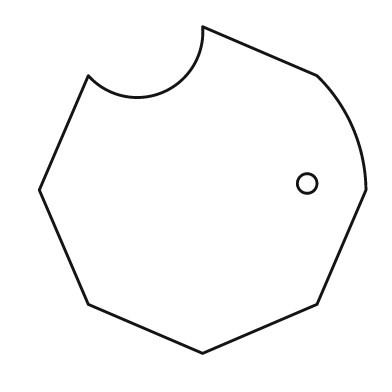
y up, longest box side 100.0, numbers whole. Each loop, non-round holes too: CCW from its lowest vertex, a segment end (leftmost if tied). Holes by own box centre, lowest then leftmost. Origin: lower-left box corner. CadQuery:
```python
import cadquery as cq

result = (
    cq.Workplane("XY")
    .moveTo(50.0, 0.0)
    .lineTo(85.0, 15.0)
    .lineTo(100.0, 50.0)
    .threePointArc((96.0, 69.0), (85.0, 85.0))
    .lineTo(50.0, 100.0)
    .threePointArc((38.0, 80.0), (15.0, 85.0))
    .lineTo(0.0, 50.0)
    .lineTo(15.0, 15.0)
    .close()
    .moveTo(82.0, 52.0)
    .circle(3.0)
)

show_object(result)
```